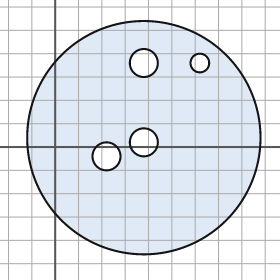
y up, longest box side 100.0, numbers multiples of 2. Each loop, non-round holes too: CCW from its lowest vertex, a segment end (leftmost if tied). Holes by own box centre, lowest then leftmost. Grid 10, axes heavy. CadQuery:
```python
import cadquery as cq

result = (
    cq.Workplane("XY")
    .moveTo(38.0, 4.0)
    .circle(50.0)
    .moveTo(22.0, -4.0)
    .circle(6.0)
    .moveTo(38.0, 2.0)
    .circle(6.0)
    .moveTo(38.0, 36.0)
    .circle(6.0)
    .moveTo(62.0, 36.0)
    .circle(4.0)
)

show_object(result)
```